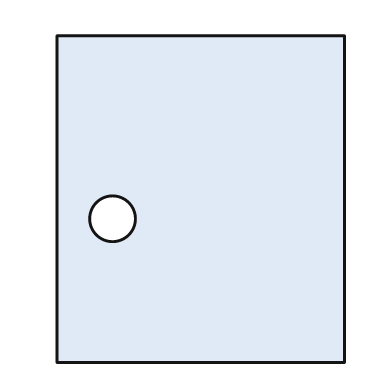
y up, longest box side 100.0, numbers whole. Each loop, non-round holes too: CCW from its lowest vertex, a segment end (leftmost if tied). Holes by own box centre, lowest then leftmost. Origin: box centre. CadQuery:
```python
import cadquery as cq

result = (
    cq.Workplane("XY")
    .moveTo(-44.0, -50.0)
    .lineTo(44.0, -50.0)
    .lineTo(44.0, 50.0)
    .lineTo(-44.0, 50.0)
    .close()
    .moveTo(-27.0, -6.0)
    .circle(7.0)
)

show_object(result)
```